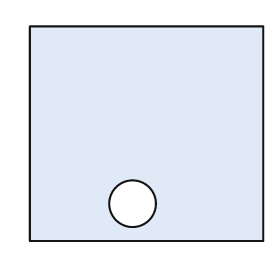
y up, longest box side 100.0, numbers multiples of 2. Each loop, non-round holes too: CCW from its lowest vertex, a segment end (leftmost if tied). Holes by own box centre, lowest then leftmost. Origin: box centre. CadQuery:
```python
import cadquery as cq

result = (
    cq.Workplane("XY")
    .moveTo(-50.0, -46.0)
    .lineTo(50.0, -46.0)
    .lineTo(50.0, 46.0)
    .lineTo(-50.0, 46.0)
    .close()
    .moveTo(-6.0, -30.0)
    .circle(10.0)
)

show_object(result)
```